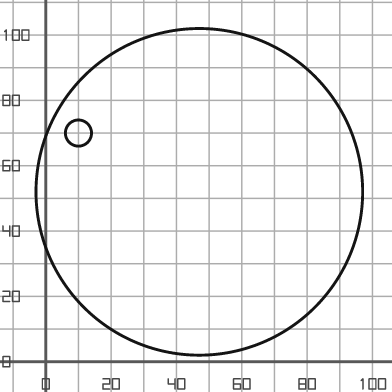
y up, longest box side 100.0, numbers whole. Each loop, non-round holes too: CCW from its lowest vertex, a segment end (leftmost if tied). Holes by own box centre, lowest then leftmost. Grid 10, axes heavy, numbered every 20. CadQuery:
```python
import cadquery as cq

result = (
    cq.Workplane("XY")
    .moveTo(47.0, 52.0)
    .circle(50.0)
    .moveTo(10.0, 70.0)
    .circle(4.0)
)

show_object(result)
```